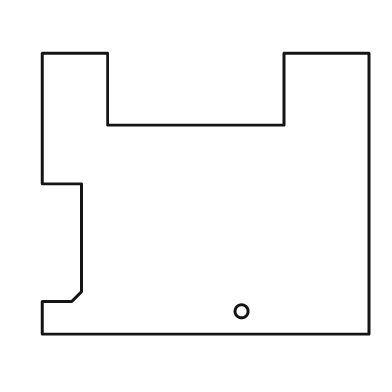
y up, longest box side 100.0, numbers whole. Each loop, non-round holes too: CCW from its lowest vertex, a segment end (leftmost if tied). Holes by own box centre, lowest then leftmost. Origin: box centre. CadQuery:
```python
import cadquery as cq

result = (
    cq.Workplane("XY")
    .moveTo(-50.0, -43.0)
    .lineTo(50.0, -43.0)
    .lineTo(50.0, 43.0)
    .lineTo(24.0, 43.0)
    .lineTo(24.0, 21.0)
    .lineTo(-30.0, 21.0)
    .lineTo(-30.0, 43.0)
    .lineTo(-50.0, 43.0)
    .lineTo(-50.0, 3.0)
    .lineTo(-38.0, 3.0)
    .lineTo(-38.0, -30.0)
    .lineTo(-41.0, -33.0)
    .lineTo(-50.0, -33.0)
    .close()
    .moveTo(11.0, -36.0)
    .circle(2.0)
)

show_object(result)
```